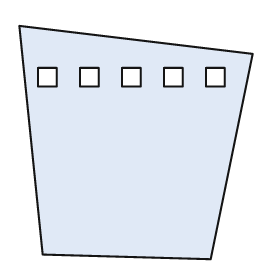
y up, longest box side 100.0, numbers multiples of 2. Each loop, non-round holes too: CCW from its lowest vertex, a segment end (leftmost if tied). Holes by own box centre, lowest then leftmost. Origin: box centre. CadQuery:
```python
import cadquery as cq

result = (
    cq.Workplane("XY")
    .moveTo(32.0, -50.0)
    .lineTo(50.0, 38.0)
    .lineTo(-50.0, 50.0)
    .lineTo(-40.0, -48.0)
    .close()
    .moveTo(-42.0, 24.0)
    .lineTo(-34.0, 24.0)
    .lineTo(-34.0, 32.0)
    .lineTo(-42.0, 32.0)
    .close()
    .moveTo(-24.0, 24.0)
    .lineTo(-16.0, 24.0)
    .lineTo(-16.0, 32.0)
    .lineTo(-24.0, 32.0)
    .close()
    .moveTo(-6.0, 24.0)
    .lineTo(2.0, 24.0)
    .lineTo(2.0, 32.0)
    .lineTo(-6.0, 32.0)
    .close()
    .moveTo(12.0, 24.0)
    .lineTo(20.0, 24.0)
    .lineTo(20.0, 32.0)
    .lineTo(12.0, 32.0)
    .close()
    .moveTo(30.0, 24.0)
    .lineTo(38.0, 24.0)
    .lineTo(38.0, 32.0)
    .lineTo(30.0, 32.0)
    .close()
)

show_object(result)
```